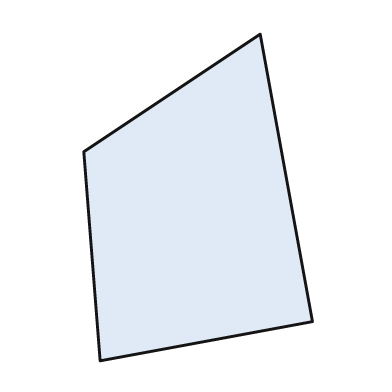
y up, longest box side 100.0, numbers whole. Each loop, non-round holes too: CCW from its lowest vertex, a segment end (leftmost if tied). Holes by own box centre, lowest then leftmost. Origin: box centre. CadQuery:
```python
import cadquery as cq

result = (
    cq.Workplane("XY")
    .moveTo(-30.0, -50.0)
    .lineTo(35.0, -38.0)
    .lineTo(19.0, 50.0)
    .lineTo(-35.0, 14.0)
    .close()
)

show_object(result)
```